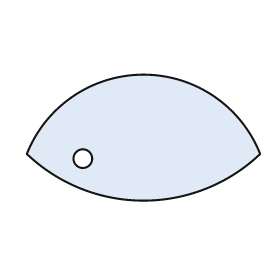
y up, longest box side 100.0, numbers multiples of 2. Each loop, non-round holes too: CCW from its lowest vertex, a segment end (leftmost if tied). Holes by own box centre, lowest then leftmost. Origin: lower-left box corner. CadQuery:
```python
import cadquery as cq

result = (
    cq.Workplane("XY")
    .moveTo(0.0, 20.0)
    .threePointArc((50.0, 0.0), (100.0, 20.0))
    .threePointArc((50.0, 54.0), (0.0, 20.0))
    .close()
    .moveTo(24.0, 18.0)
    .circle(4.0)
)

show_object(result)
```